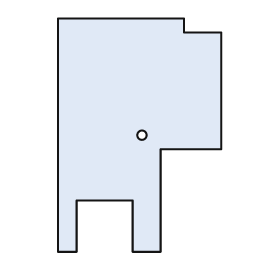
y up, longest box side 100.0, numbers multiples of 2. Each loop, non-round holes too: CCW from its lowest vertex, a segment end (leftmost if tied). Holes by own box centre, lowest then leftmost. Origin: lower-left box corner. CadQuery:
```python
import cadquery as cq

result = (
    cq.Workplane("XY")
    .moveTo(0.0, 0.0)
    .lineTo(8.0, 0.0)
    .lineTo(8.0, 22.0)
    .lineTo(32.0, 22.0)
    .lineTo(32.0, 0.0)
    .lineTo(44.0, 0.0)
    .lineTo(44.0, 44.0)
    .lineTo(70.0, 44.0)
    .lineTo(70.0, 94.0)
    .lineTo(54.0, 94.0)
    .lineTo(54.0, 100.0)
    .lineTo(0.0, 100.0)
    .close()
    .moveTo(36.0, 50.0)
    .circle(2.0)
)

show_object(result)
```